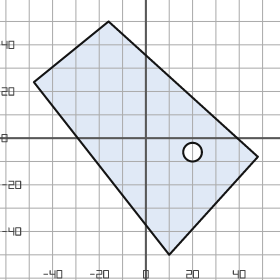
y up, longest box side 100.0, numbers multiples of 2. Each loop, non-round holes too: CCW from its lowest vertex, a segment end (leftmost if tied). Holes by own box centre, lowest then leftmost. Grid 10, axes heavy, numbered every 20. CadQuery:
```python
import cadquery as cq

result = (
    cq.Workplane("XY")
    .moveTo(10.0, -50.0)
    .lineTo(48.0, -8.0)
    .lineTo(-16.0, 50.0)
    .lineTo(-48.0, 24.0)
    .close()
    .moveTo(20.0, -6.0)
    .circle(4.0)
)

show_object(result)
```